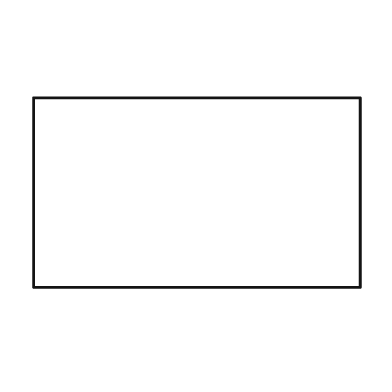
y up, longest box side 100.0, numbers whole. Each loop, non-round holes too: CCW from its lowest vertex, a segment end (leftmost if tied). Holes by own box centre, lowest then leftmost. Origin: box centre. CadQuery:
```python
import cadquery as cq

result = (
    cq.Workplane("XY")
    .moveTo(-50.0, -29.0)
    .lineTo(50.0, -29.0)
    .lineTo(50.0, 29.0)
    .lineTo(-50.0, 29.0)
    .close()
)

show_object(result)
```